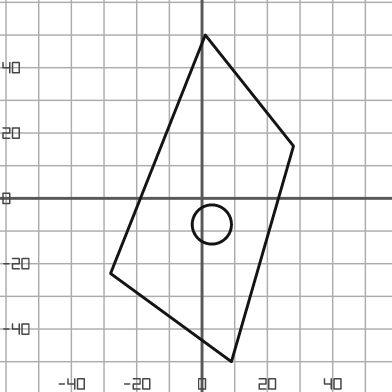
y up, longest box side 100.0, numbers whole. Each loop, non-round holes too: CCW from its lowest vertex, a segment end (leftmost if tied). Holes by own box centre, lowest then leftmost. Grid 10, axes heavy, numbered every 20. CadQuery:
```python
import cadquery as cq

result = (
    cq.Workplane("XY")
    .moveTo(9.0, -50.0)
    .lineTo(28.0, 16.0)
    .lineTo(1.0, 50.0)
    .lineTo(-28.0, -23.0)
    .close()
    .moveTo(3.0, -8.0)
    .circle(6.0)
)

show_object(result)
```